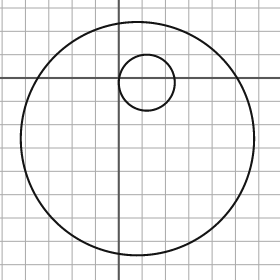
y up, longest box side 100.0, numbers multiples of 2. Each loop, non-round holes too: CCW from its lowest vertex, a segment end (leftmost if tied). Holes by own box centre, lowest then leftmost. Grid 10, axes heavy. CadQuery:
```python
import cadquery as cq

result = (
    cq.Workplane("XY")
    .moveTo(8.0, -26.0)
    .circle(50.0)
    .moveTo(12.0, -2.0)
    .circle(12.0)
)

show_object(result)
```